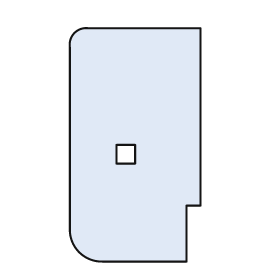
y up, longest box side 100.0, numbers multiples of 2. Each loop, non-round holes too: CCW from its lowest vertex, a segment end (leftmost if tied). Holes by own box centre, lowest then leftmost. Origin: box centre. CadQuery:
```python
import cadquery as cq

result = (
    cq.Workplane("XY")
    .moveTo(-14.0, -50.0)
    .lineTo(22.0, -50.0)
    .lineTo(22.0, -26.0)
    .lineTo(28.0, -26.0)
    .lineTo(28.0, 50.0)
    .lineTo(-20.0, 50.0)
    .threePointArc((-26.0, 48.0), (-28.0, 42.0))
    .lineTo(-28.0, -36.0)
    .threePointArc((-24.0, -46.0), (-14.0, -50.0))
    .close()
    .moveTo(-8.0, -8.0)
    .lineTo(0.0, -8.0)
    .lineTo(0.0, 0.0)
    .lineTo(-8.0, 0.0)
    .close()
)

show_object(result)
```